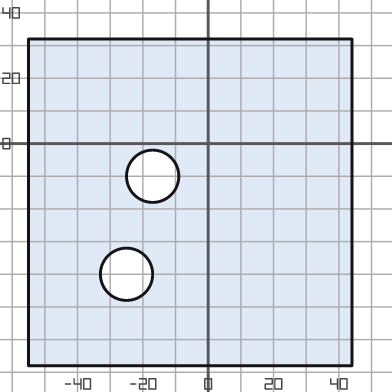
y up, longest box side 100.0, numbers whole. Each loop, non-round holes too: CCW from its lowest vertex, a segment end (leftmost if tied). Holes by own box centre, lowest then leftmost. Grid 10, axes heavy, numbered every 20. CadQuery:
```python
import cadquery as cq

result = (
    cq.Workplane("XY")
    .moveTo(-55.0, -68.0)
    .lineTo(44.0, -68.0)
    .lineTo(44.0, 32.0)
    .lineTo(-55.0, 32.0)
    .close()
    .moveTo(-25.0, -40.0)
    .circle(8.0)
    .moveTo(-17.0, -10.0)
    .circle(8.0)
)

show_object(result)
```